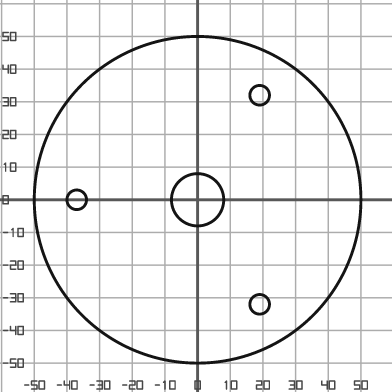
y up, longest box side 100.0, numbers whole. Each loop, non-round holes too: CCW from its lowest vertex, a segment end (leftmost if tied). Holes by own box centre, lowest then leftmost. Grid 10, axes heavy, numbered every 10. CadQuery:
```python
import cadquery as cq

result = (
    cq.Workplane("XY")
    .moveTo(0.0, 0.0)
    .circle(50.0)
    .moveTo(19.0, -32.0)
    .circle(3.0)
    .moveTo(-37.0, 0.0)
    .circle(3.0)
    .moveTo(0.0, 0.0)
    .circle(8.0)
    .moveTo(19.0, 32.0)
    .circle(3.0)
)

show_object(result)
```